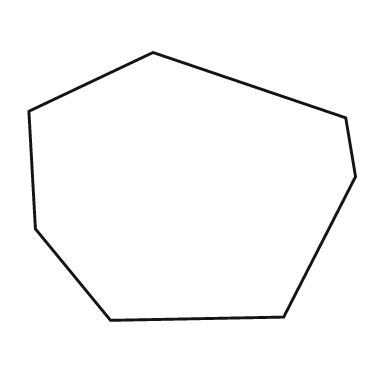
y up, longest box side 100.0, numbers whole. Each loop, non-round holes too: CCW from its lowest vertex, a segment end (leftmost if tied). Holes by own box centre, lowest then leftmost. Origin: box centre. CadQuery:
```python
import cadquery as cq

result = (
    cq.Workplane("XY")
    .moveTo(-25.0, -41.0)
    .lineTo(28.0, -40.0)
    .lineTo(50.0, 3.0)
    .lineTo(47.0, 21.0)
    .lineTo(-12.0, 41.0)
    .lineTo(-50.0, 23.0)
    .lineTo(-48.0, -13.0)
    .close()
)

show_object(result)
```